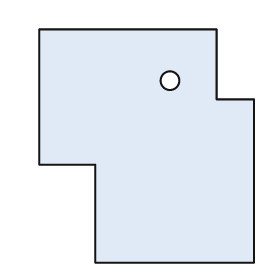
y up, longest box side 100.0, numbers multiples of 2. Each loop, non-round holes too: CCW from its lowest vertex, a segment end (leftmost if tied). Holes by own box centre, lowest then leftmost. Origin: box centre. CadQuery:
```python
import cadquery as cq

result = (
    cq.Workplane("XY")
    .moveTo(-22.0, -50.0)
    .lineTo(46.0, -50.0)
    .lineTo(46.0, 20.0)
    .lineTo(30.0, 20.0)
    .lineTo(30.0, 50.0)
    .lineTo(-46.0, 50.0)
    .lineTo(-46.0, -8.0)
    .lineTo(-22.0, -8.0)
    .close()
    .moveTo(10.0, 28.0)
    .circle(4.0)
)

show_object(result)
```